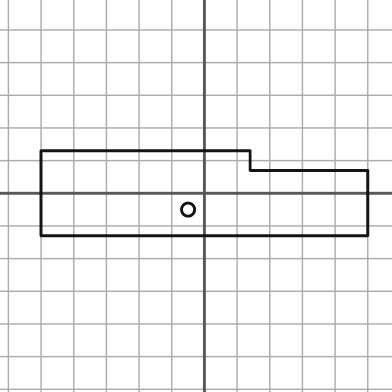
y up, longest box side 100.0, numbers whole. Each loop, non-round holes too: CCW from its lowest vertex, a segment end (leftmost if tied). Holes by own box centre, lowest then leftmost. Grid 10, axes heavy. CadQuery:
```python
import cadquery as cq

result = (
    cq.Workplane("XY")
    .moveTo(-50.0, -13.0)
    .lineTo(50.0, -13.0)
    .lineTo(50.0, 7.0)
    .lineTo(14.0, 7.0)
    .lineTo(14.0, 13.0)
    .lineTo(-50.0, 13.0)
    .close()
    .moveTo(-5.0, -5.0)
    .circle(2.0)
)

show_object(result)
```